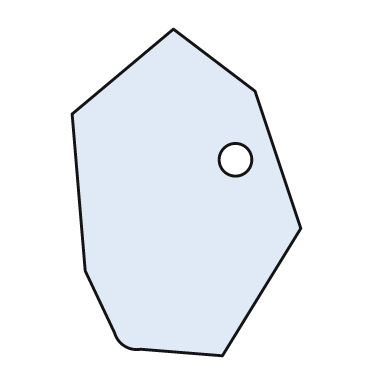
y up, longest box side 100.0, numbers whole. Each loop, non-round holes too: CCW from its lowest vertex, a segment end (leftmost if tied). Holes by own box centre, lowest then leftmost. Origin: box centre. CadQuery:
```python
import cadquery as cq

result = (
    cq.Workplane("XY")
    .moveTo(11.0, -50.0)
    .lineTo(35.0, -11.0)
    .lineTo(21.0, 31.0)
    .lineTo(-4.0, 50.0)
    .lineTo(-35.0, 24.0)
    .lineTo(-31.0, -24.0)
    .lineTo(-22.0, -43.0)
    .threePointArc((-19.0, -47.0), (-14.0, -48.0))
    .close()
    .moveTo(15.0, 10.0)
    .circle(5.0)
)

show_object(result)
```